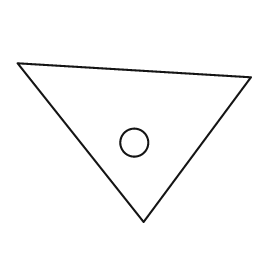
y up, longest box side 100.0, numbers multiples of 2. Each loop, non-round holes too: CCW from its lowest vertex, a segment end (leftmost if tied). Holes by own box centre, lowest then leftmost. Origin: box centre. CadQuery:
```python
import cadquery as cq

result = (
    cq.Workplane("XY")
    .moveTo(4.0, -34.0)
    .lineTo(50.0, 28.0)
    .lineTo(-50.0, 34.0)
    .close()
    .moveTo(0.0, 0.0)
    .circle(6.0)
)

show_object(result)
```